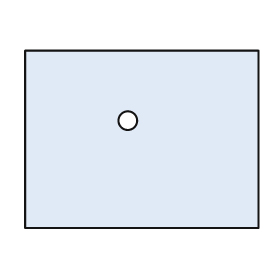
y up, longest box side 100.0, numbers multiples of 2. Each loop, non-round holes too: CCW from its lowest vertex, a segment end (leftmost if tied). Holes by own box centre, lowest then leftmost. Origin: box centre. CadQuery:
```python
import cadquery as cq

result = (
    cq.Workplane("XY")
    .moveTo(-50.0, -38.0)
    .lineTo(50.0, -38.0)
    .lineTo(50.0, 38.0)
    .lineTo(-50.0, 38.0)
    .close()
    .moveTo(-6.0, 8.0)
    .circle(4.0)
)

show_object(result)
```